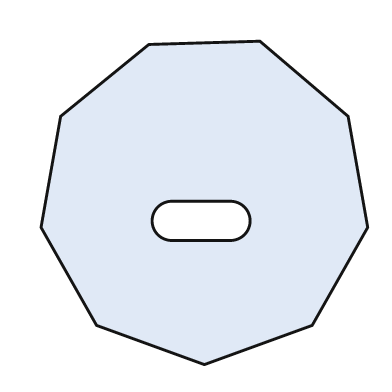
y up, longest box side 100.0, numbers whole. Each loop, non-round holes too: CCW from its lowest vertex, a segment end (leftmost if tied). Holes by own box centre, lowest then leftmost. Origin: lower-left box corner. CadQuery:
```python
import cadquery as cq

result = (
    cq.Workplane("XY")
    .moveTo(50.0, 0.0)
    .lineTo(83.0, 12.0)
    .lineTo(100.0, 42.0)
    .lineTo(94.0, 76.0)
    .lineTo(67.0, 99.0)
    .lineTo(33.0, 98.0)
    .lineTo(6.0, 76.0)
    .lineTo(0.0, 42.0)
    .lineTo(17.0, 12.0)
    .close()
    .moveTo(40.0, 38.0)
    .lineTo(58.0, 38.0)
    .threePointArc((64.0, 44.0), (58.0, 50.0))
    .lineTo(40.0, 50.0)
    .threePointArc((34.0, 44.0), (40.0, 38.0))
    .close()
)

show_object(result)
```